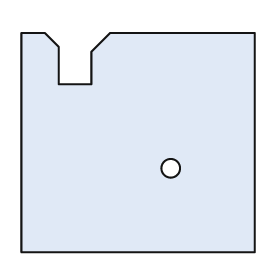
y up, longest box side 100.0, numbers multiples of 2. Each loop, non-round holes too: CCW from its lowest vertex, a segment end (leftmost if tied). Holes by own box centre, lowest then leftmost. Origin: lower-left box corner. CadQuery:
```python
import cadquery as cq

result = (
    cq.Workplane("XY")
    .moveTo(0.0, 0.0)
    .lineTo(100.0, 0.0)
    .lineTo(100.0, 94.0)
    .lineTo(38.0, 94.0)
    .lineTo(30.0, 86.0)
    .lineTo(30.0, 72.0)
    .lineTo(16.0, 72.0)
    .lineTo(16.0, 88.0)
    .lineTo(10.0, 94.0)
    .lineTo(0.0, 94.0)
    .close()
    .moveTo(64.0, 36.0)
    .circle(4.0)
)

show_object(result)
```